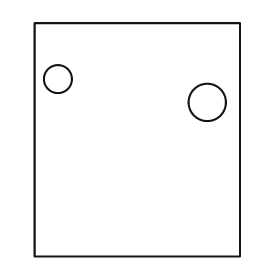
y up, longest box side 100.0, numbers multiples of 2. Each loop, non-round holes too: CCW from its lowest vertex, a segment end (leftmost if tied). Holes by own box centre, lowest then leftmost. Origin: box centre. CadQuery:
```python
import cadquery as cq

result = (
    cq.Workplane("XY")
    .moveTo(-44.0, -50.0)
    .lineTo(44.0, -50.0)
    .lineTo(44.0, 50.0)
    .lineTo(-44.0, 50.0)
    .close()
    .moveTo(30.0, 16.0)
    .circle(8.0)
    .moveTo(-34.0, 26.0)
    .circle(6.0)
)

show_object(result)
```